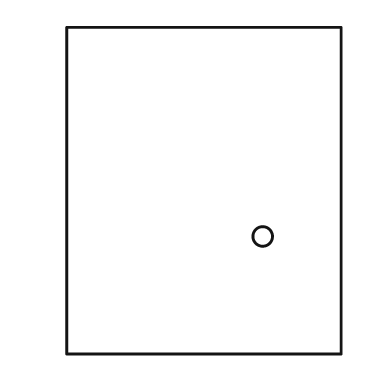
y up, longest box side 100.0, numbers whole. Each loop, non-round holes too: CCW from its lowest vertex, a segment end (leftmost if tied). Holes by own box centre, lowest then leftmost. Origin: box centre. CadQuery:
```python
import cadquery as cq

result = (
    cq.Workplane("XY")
    .moveTo(-42.0, -50.0)
    .lineTo(42.0, -50.0)
    .lineTo(42.0, 50.0)
    .lineTo(-42.0, 50.0)
    .close()
    .moveTo(18.0, -14.0)
    .circle(3.0)
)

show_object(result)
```